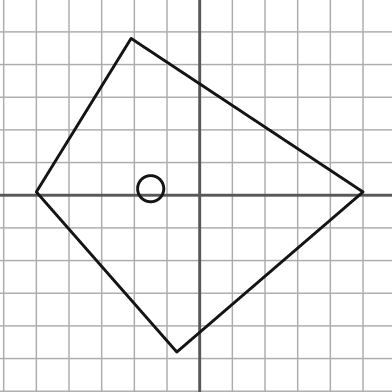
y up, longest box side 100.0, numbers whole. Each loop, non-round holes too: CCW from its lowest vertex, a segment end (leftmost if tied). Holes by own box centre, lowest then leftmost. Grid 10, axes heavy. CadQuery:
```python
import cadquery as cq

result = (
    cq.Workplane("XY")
    .moveTo(-7.0, -48.0)
    .lineTo(50.0, 1.0)
    .lineTo(-21.0, 48.0)
    .lineTo(-50.0, 1.0)
    .close()
    .moveTo(-15.0, 2.0)
    .circle(4.0)
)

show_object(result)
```